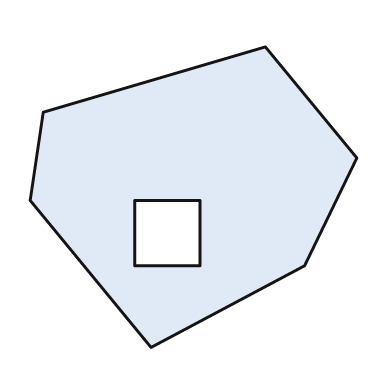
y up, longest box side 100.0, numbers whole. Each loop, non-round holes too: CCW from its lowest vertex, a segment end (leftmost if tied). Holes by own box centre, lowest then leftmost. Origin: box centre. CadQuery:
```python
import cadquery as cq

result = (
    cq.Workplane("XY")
    .moveTo(-13.0, -46.0)
    .lineTo(34.0, -21.0)
    .lineTo(50.0, 12.0)
    .lineTo(22.0, 46.0)
    .lineTo(-46.0, 26.0)
    .lineTo(-50.0, -1.0)
    .close()
    .moveTo(-18.0, -21.0)
    .lineTo(2.0, -21.0)
    .lineTo(2.0, -1.0)
    .lineTo(-18.0, -1.0)
    .close()
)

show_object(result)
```